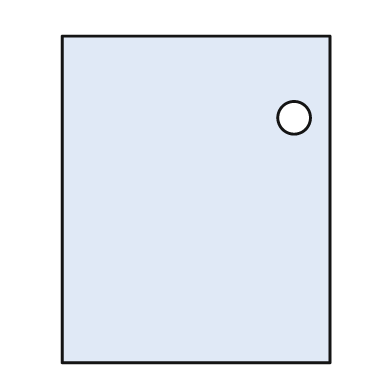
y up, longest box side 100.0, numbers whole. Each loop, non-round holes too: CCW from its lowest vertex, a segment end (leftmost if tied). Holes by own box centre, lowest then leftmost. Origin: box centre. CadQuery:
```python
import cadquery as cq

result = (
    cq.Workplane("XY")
    .moveTo(-41.0, -50.0)
    .lineTo(41.0, -50.0)
    .lineTo(41.0, 50.0)
    .lineTo(-41.0, 50.0)
    .close()
    .moveTo(30.0, 25.0)
    .circle(5.0)
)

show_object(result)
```